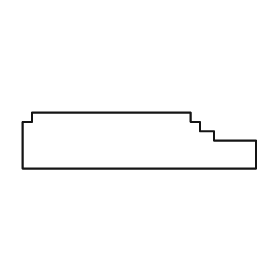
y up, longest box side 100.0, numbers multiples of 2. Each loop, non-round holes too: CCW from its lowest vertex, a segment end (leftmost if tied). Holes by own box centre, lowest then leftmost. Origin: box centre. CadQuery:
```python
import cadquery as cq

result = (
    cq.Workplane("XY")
    .moveTo(-50.0, -12.0)
    .lineTo(50.0, -12.0)
    .lineTo(50.0, 0.0)
    .lineTo(32.0, 0.0)
    .lineTo(32.0, 4.0)
    .lineTo(26.0, 4.0)
    .lineTo(26.0, 8.0)
    .lineTo(22.0, 8.0)
    .lineTo(22.0, 12.0)
    .lineTo(-46.0, 12.0)
    .lineTo(-46.0, 8.0)
    .lineTo(-50.0, 8.0)
    .close()
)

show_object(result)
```